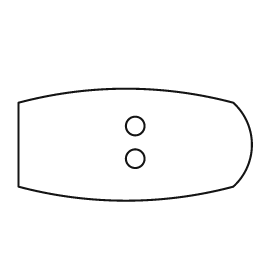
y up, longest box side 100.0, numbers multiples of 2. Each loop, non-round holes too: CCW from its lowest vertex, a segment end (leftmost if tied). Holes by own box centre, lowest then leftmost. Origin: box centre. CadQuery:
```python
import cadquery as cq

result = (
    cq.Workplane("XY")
    .moveTo(-50.0, -18.0)
    .threePointArc((-4.0, -24.0), (42.0, -18.0))
    .threePointArc((50.0, 0.0), (42.0, 18.0))
    .threePointArc((-4.0, 24.0), (-50.0, 18.0))
    .close()
    .moveTo(0.0, -6.0)
    .circle(4.0)
    .moveTo(0.0, 8.0)
    .circle(4.0)
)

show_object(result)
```